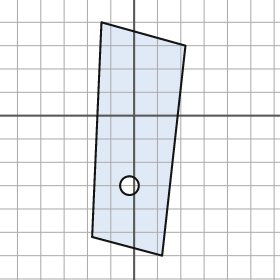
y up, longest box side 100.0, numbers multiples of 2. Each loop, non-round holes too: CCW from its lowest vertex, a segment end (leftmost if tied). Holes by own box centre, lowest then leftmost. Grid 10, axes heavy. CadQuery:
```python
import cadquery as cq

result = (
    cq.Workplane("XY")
    .moveTo(12.0, -60.0)
    .lineTo(22.0, 30.0)
    .lineTo(-14.0, 40.0)
    .lineTo(-18.0, -52.0)
    .close()
    .moveTo(-2.0, -30.0)
    .circle(4.0)
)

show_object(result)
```